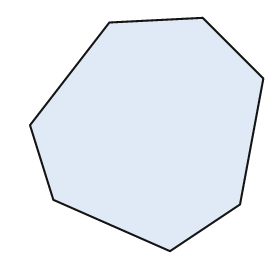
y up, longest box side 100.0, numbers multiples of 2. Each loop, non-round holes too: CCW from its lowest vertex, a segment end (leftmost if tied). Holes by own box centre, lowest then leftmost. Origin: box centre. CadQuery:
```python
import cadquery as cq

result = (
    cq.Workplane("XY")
    .moveTo(10.0, -50.0)
    .lineTo(40.0, -30.0)
    .lineTo(50.0, 24.0)
    .lineTo(24.0, 50.0)
    .lineTo(-16.0, 48.0)
    .lineTo(-50.0, 4.0)
    .lineTo(-40.0, -28.0)
    .close()
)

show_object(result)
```